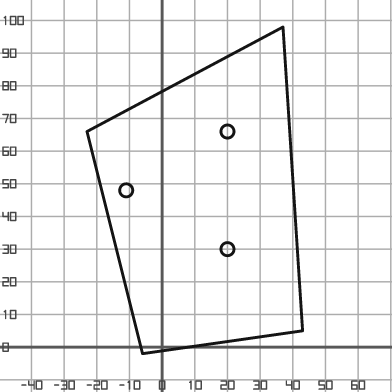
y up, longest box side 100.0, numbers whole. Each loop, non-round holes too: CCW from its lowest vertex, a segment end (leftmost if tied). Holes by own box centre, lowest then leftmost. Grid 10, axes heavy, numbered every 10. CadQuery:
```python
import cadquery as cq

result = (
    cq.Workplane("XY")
    .moveTo(-6.0, -2.0)
    .lineTo(43.0, 5.0)
    .lineTo(37.0, 98.0)
    .lineTo(-23.0, 66.0)
    .close()
    .moveTo(20.0, 30.0)
    .circle(2.0)
    .moveTo(-11.0, 48.0)
    .circle(2.0)
    .moveTo(20.0, 66.0)
    .circle(2.0)
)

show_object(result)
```